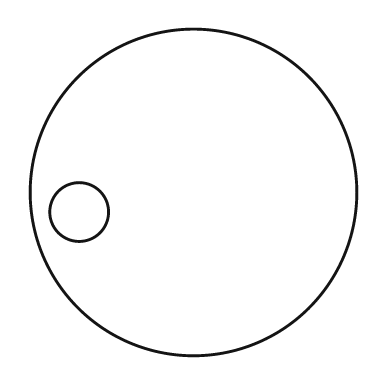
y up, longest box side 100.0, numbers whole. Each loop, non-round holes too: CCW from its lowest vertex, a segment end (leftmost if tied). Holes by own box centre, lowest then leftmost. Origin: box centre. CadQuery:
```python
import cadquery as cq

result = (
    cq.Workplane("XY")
    .moveTo(0.0, 0.0)
    .circle(50.0)
    .moveTo(-35.0, -6.0)
    .circle(9.0)
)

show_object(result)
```